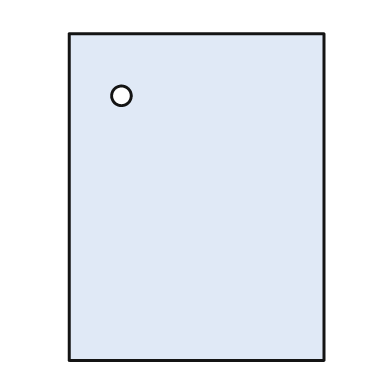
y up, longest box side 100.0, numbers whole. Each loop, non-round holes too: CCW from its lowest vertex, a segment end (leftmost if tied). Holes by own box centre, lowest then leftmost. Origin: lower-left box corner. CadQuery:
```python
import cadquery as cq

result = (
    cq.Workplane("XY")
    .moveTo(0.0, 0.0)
    .lineTo(78.0, 0.0)
    .lineTo(78.0, 100.0)
    .lineTo(0.0, 100.0)
    .close()
    .moveTo(16.0, 81.0)
    .circle(3.0)
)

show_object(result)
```